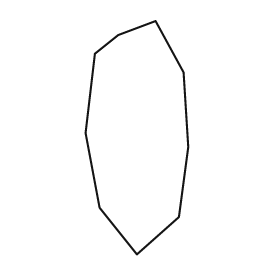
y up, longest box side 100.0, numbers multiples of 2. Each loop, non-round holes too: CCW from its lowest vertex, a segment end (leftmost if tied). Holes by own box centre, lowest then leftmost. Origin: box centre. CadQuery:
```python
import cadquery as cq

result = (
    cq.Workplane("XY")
    .moveTo(0.0, -50.0)
    .lineTo(18.0, -34.0)
    .lineTo(22.0, -4.0)
    .lineTo(20.0, 28.0)
    .lineTo(8.0, 50.0)
    .lineTo(-8.0, 44.0)
    .lineTo(-18.0, 36.0)
    .lineTo(-22.0, 2.0)
    .lineTo(-16.0, -30.0)
    .close()
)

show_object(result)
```